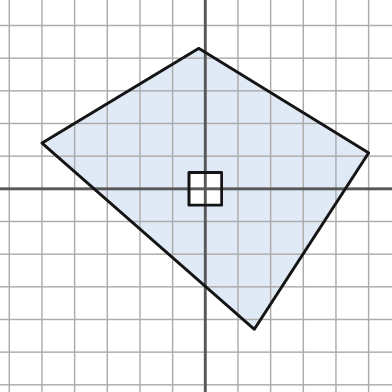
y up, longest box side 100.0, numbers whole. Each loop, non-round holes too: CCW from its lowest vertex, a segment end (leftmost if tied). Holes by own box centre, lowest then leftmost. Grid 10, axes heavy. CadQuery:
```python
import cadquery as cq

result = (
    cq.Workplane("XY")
    .moveTo(15.0, -43.0)
    .lineTo(50.0, 11.0)
    .lineTo(-2.0, 43.0)
    .lineTo(-50.0, 14.0)
    .close()
    .moveTo(-5.0, -5.0)
    .lineTo(5.0, -5.0)
    .lineTo(5.0, 5.0)
    .lineTo(-5.0, 5.0)
    .close()
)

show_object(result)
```